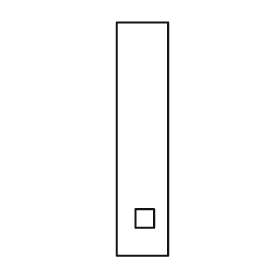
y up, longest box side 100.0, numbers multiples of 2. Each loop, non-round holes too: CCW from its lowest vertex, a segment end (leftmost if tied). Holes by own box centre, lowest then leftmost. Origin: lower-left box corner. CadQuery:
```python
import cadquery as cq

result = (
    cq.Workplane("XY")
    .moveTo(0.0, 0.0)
    .lineTo(22.0, 0.0)
    .lineTo(22.0, 100.0)
    .lineTo(0.0, 100.0)
    .close()
    .moveTo(8.0, 12.0)
    .lineTo(16.0, 12.0)
    .lineTo(16.0, 20.0)
    .lineTo(8.0, 20.0)
    .close()
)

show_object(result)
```